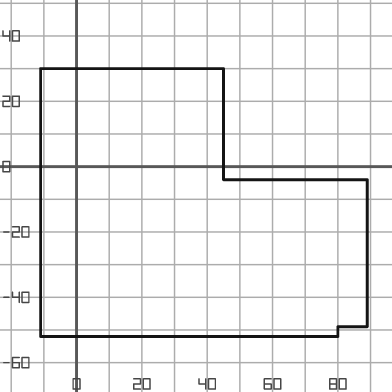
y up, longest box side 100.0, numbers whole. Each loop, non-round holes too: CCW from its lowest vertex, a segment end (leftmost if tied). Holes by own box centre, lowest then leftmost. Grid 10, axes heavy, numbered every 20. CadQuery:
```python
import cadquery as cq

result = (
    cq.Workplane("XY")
    .moveTo(-11.0, -52.0)
    .lineTo(80.0, -52.0)
    .lineTo(80.0, -49.0)
    .lineTo(89.0, -49.0)
    .lineTo(89.0, -4.0)
    .lineTo(45.0, -4.0)
    .lineTo(45.0, 30.0)
    .lineTo(-11.0, 30.0)
    .close()
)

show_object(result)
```